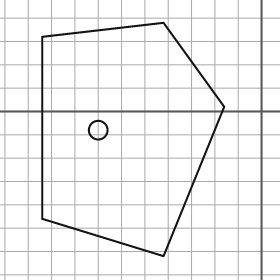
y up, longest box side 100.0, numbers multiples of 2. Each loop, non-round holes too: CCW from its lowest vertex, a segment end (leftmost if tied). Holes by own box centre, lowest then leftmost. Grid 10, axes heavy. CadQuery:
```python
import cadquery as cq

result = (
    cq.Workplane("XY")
    .moveTo(-42.0, -62.0)
    .lineTo(-16.0, 2.0)
    .lineTo(-42.0, 38.0)
    .lineTo(-94.0, 32.0)
    .lineTo(-94.0, -46.0)
    .close()
    .moveTo(-70.0, -8.0)
    .circle(4.0)
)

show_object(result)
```